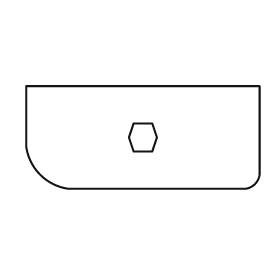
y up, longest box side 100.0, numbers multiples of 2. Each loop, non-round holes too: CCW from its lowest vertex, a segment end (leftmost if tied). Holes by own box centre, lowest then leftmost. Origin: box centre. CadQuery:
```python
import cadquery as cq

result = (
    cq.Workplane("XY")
    .moveTo(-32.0, -22.0)
    .lineTo(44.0, -22.0)
    .threePointArc((48.0, -20.0), (50.0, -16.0))
    .lineTo(50.0, 22.0)
    .lineTo(-50.0, 22.0)
    .lineTo(-50.0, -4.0)
    .threePointArc((-44.0, -16.0), (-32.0, -22.0))
    .close()
    .moveTo(-4.0, -6.0)
    .lineTo(4.0, -6.0)
    .lineTo(6.0, 0.0)
    .lineTo(4.0, 6.0)
    .lineTo(-4.0, 6.0)
    .lineTo(-6.0, 0.0)
    .close()
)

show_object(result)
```